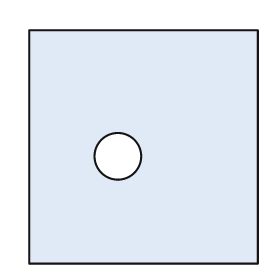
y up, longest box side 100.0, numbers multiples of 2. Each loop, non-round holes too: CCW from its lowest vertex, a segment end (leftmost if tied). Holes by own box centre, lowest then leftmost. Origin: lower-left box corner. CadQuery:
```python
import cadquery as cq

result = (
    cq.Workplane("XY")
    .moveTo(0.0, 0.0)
    .lineTo(98.0, 0.0)
    .lineTo(98.0, 100.0)
    .lineTo(0.0, 100.0)
    .close()
    .moveTo(38.0, 46.0)
    .circle(10.0)
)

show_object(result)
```